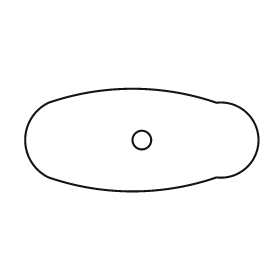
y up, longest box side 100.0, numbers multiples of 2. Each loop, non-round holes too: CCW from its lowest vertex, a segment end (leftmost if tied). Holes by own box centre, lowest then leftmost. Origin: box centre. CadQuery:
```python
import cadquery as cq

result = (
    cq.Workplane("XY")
    .moveTo(-40.0, -16.0)
    .threePointArc((-4.0, -22.0), (32.0, -16.0))
    .threePointArc((50.0, 0.0), (32.0, 16.0))
    .threePointArc((-4.0, 22.0), (-40.0, 16.0))
    .threePointArc((-50.0, 0.0), (-40.0, -16.0))
    .close()
    .moveTo(0.0, 0.0)
    .circle(4.0)
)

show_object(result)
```